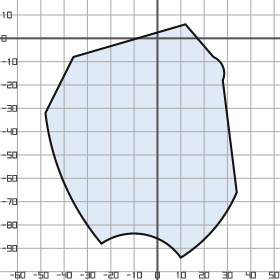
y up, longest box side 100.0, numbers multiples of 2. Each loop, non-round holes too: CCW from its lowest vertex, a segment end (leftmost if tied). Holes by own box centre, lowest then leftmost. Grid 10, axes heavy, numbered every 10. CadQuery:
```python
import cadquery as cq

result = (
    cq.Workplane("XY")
    .moveTo(10.0, -94.0)
    .threePointArc((24.0, -82.0), (34.0, -66.0))
    .lineTo(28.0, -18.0)
    .threePointArc((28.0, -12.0), (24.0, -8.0))
    .lineTo(12.0, 6.0)
    .lineTo(-36.0, -8.0)
    .lineTo(-48.0, -32.0)
    .threePointArc((-40.0, -62.0), (-24.0, -88.0))
    .threePointArc((-6.0, -84.0), (10.0, -94.0))
    .close()
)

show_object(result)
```